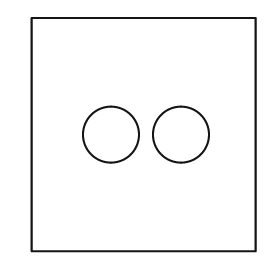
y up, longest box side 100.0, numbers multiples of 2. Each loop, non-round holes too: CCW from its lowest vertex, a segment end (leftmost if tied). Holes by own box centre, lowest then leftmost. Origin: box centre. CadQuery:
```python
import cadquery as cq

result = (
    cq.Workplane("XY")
    .moveTo(-48.0, -50.0)
    .lineTo(48.0, -50.0)
    .lineTo(48.0, 50.0)
    .lineTo(-48.0, 50.0)
    .close()
    .moveTo(-14.0, 0.0)
    .circle(12.0)
    .moveTo(16.0, 0.0)
    .circle(12.0)
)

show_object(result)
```